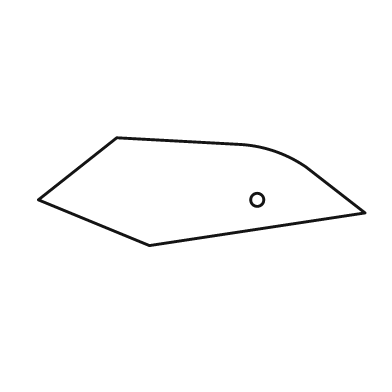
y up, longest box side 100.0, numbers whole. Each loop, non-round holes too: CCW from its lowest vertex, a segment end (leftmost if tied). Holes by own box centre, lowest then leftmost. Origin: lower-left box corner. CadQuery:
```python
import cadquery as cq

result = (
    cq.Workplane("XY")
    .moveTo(34.0, 0.0)
    .lineTo(100.0, 10.0)
    .lineTo(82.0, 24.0)
    .threePointArc((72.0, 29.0), (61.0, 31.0))
    .lineTo(24.0, 33.0)
    .lineTo(0.0, 14.0)
    .close()
    .moveTo(67.0, 14.0)
    .circle(2.0)
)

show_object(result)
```